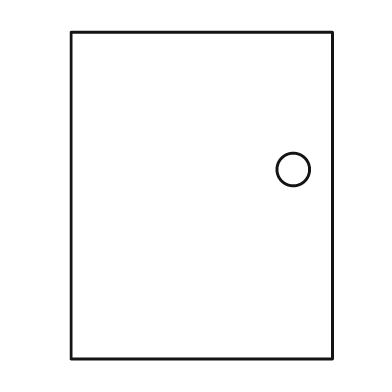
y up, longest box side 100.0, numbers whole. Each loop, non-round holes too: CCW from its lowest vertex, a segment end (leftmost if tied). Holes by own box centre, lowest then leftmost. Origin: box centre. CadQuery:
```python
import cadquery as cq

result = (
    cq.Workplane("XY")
    .moveTo(-40.0, -50.0)
    .lineTo(40.0, -50.0)
    .lineTo(40.0, 50.0)
    .lineTo(-40.0, 50.0)
    .close()
    .moveTo(28.0, 8.0)
    .circle(5.0)
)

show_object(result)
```